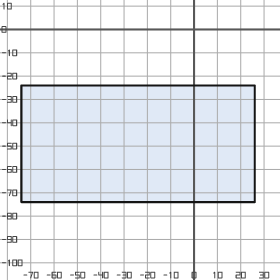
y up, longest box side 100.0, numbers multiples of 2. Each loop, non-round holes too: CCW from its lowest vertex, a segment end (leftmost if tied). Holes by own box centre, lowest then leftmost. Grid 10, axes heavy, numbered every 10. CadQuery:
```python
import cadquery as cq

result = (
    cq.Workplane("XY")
    .moveTo(-74.0, -74.0)
    .lineTo(26.0, -74.0)
    .lineTo(26.0, -24.0)
    .lineTo(-74.0, -24.0)
    .close()
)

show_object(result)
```